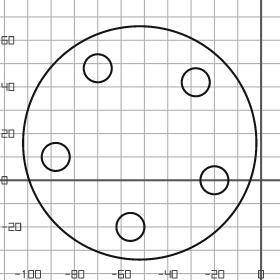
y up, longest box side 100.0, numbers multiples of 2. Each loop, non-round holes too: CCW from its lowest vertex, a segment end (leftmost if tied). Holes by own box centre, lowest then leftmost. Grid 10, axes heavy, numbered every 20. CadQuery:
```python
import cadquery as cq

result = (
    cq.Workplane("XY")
    .moveTo(-52.0, 16.0)
    .circle(50.0)
    .moveTo(-56.0, -20.0)
    .circle(6.0)
    .moveTo(-20.0, 0.0)
    .circle(6.0)
    .moveTo(-88.0, 10.0)
    .circle(6.0)
    .moveTo(-28.0, 42.0)
    .circle(6.0)
    .moveTo(-70.0, 48.0)
    .circle(6.0)
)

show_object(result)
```